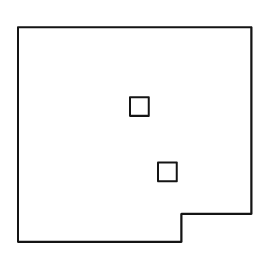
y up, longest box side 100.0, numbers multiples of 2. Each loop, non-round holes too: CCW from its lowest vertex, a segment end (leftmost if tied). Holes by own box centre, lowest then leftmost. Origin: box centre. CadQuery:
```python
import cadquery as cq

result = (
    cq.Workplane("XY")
    .moveTo(-50.0, -46.0)
    .lineTo(20.0, -46.0)
    .lineTo(20.0, -34.0)
    .lineTo(50.0, -34.0)
    .lineTo(50.0, 46.0)
    .lineTo(-50.0, 46.0)
    .close()
    .moveTo(10.0, -20.0)
    .lineTo(18.0, -20.0)
    .lineTo(18.0, -12.0)
    .lineTo(10.0, -12.0)
    .close()
    .moveTo(-2.0, 8.0)
    .lineTo(6.0, 8.0)
    .lineTo(6.0, 16.0)
    .lineTo(-2.0, 16.0)
    .close()
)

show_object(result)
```